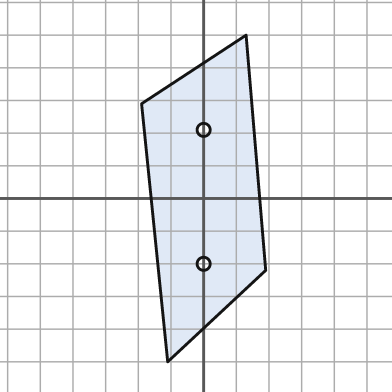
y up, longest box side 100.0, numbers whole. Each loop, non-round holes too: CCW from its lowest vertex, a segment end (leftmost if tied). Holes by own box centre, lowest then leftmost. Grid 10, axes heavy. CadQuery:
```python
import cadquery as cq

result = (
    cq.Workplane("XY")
    .moveTo(-11.0, -50.0)
    .lineTo(19.0, -22.0)
    .lineTo(13.0, 50.0)
    .lineTo(-19.0, 29.0)
    .close()
    .moveTo(0.0, -20.0)
    .circle(2.0)
    .moveTo(0.0, 21.0)
    .circle(2.0)
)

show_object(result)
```